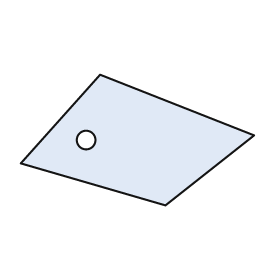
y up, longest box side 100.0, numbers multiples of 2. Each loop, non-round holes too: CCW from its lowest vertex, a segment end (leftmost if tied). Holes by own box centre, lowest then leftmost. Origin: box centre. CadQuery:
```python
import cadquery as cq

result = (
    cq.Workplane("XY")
    .moveTo(12.0, -28.0)
    .lineTo(50.0, 2.0)
    .lineTo(-16.0, 28.0)
    .lineTo(-50.0, -10.0)
    .close()
    .moveTo(-22.0, 0.0)
    .circle(4.0)
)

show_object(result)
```